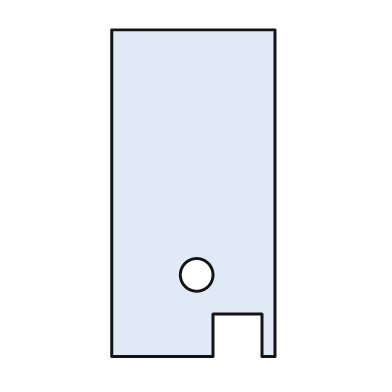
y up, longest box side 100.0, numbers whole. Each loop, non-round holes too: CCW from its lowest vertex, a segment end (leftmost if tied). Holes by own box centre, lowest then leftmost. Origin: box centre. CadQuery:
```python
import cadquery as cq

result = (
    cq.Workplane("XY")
    .moveTo(-25.0, -50.0)
    .lineTo(6.0, -50.0)
    .lineTo(6.0, -37.0)
    .lineTo(21.0, -37.0)
    .lineTo(21.0, -50.0)
    .lineTo(25.0, -50.0)
    .lineTo(25.0, 50.0)
    .lineTo(-25.0, 50.0)
    .close()
    .moveTo(1.0, -25.0)
    .circle(5.0)
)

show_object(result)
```